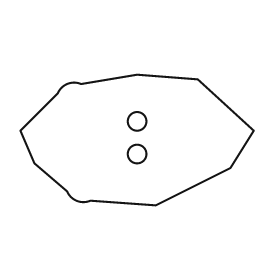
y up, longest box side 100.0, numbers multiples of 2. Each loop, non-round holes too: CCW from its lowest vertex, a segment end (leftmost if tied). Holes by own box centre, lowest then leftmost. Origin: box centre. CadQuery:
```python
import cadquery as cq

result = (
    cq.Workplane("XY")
    .moveTo(8.0, -28.0)
    .lineTo(40.0, -12.0)
    .lineTo(50.0, 4.0)
    .lineTo(26.0, 26.0)
    .lineTo(0.0, 28.0)
    .lineTo(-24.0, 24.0)
    .threePointArc((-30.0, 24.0), (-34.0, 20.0))
    .lineTo(-50.0, 4.0)
    .lineTo(-44.0, -10.0)
    .lineTo(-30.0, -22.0)
    .threePointArc((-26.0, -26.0), (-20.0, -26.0))
    .close()
    .moveTo(0.0, -6.0)
    .circle(4.0)
    .moveTo(0.0, 8.0)
    .circle(4.0)
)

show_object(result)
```